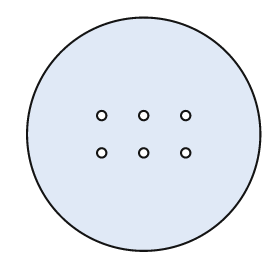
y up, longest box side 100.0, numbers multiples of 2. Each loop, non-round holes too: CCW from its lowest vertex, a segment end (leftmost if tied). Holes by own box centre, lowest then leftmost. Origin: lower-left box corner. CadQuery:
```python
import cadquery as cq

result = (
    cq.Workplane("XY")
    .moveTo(50.0, 50.0)
    .circle(50.0)
    .moveTo(32.0, 42.0)
    .circle(2.0)
    .moveTo(50.0, 42.0)
    .circle(2.0)
    .moveTo(68.0, 42.0)
    .circle(2.0)
    .moveTo(32.0, 58.0)
    .circle(2.0)
    .moveTo(50.0, 58.0)
    .circle(2.0)
    .moveTo(68.0, 58.0)
    .circle(2.0)
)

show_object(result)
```